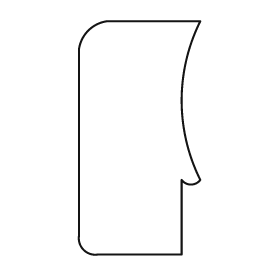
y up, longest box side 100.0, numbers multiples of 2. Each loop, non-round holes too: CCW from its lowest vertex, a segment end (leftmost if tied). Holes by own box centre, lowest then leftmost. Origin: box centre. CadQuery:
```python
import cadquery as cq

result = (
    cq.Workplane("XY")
    .moveTo(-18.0, -50.0)
    .lineTo(18.0, -50.0)
    .lineTo(18.0, -18.0)
    .threePointArc((22.0, -20.0), (26.0, -18.0))
    .threePointArc((18.0, 16.0), (26.0, 50.0))
    .lineTo(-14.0, 50.0)
    .threePointArc((-22.0, 46.0), (-26.0, 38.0))
    .lineTo(-26.0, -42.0)
    .threePointArc((-24.0, -48.0), (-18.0, -50.0))
    .close()
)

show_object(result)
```